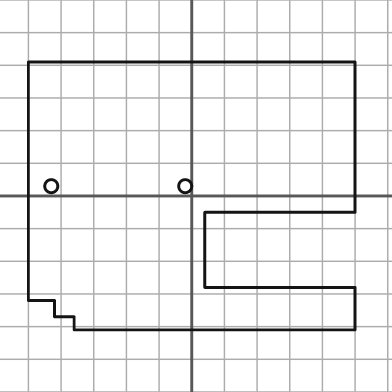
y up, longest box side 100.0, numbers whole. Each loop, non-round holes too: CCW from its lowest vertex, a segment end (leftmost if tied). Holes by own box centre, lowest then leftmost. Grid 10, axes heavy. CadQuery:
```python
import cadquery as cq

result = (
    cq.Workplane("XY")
    .moveTo(-36.0, -41.0)
    .lineTo(50.0, -41.0)
    .lineTo(50.0, -28.0)
    .lineTo(4.0, -28.0)
    .lineTo(4.0, -5.0)
    .lineTo(50.0, -5.0)
    .lineTo(50.0, 41.0)
    .lineTo(-50.0, 41.0)
    .lineTo(-50.0, -32.0)
    .lineTo(-42.0, -32.0)
    .lineTo(-42.0, -37.0)
    .lineTo(-36.0, -37.0)
    .close()
    .moveTo(-43.0, 3.0)
    .circle(2.0)
    .moveTo(-2.0, 3.0)
    .circle(2.0)
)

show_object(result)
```